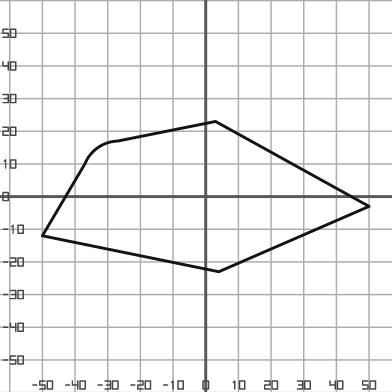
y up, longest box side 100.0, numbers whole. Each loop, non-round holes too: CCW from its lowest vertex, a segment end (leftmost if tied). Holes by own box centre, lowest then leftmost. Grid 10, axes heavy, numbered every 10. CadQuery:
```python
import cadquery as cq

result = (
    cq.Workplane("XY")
    .moveTo(4.0, -23.0)
    .lineTo(50.0, -3.0)
    .lineTo(3.0, 23.0)
    .lineTo(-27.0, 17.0)
    .threePointArc((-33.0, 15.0), (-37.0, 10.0))
    .lineTo(-50.0, -12.0)
    .close()
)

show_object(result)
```